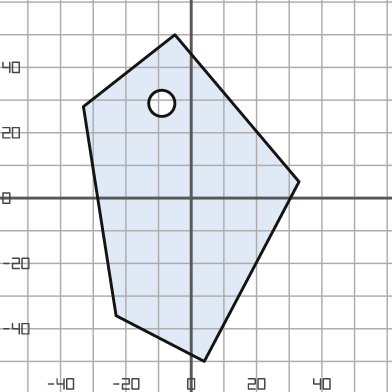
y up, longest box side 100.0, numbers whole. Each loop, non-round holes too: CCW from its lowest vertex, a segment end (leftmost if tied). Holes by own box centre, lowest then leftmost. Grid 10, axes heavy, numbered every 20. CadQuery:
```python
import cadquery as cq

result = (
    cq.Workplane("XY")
    .moveTo(4.0, -50.0)
    .lineTo(33.0, 5.0)
    .lineTo(-5.0, 50.0)
    .lineTo(-33.0, 28.0)
    .lineTo(-23.0, -36.0)
    .close()
    .moveTo(-9.0, 29.0)
    .circle(4.0)
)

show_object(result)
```